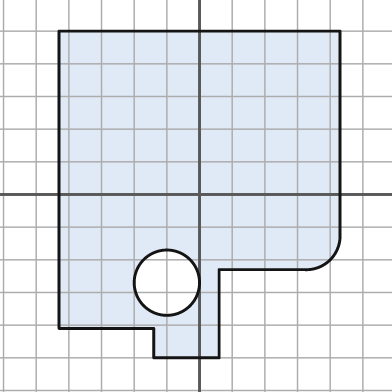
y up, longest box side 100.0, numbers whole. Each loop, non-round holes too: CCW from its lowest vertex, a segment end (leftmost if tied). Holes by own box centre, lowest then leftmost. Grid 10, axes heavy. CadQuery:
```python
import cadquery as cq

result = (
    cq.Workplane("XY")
    .moveTo(-14.0, -50.0)
    .lineTo(6.0, -50.0)
    .lineTo(6.0, -23.0)
    .lineTo(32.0, -23.0)
    .threePointArc((40.0, -20.0), (43.0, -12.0))
    .lineTo(43.0, 50.0)
    .lineTo(-43.0, 50.0)
    .lineTo(-43.0, -41.0)
    .lineTo(-14.0, -41.0)
    .close()
    .moveTo(-10.0, -27.0)
    .circle(10.0)
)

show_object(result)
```